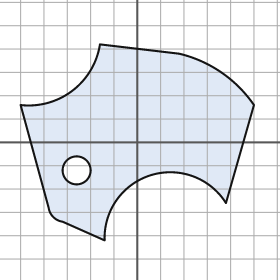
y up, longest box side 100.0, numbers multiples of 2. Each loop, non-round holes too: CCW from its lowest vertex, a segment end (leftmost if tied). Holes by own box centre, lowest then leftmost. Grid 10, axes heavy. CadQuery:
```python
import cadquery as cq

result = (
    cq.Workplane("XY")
    .moveTo(-14.0, -42.0)
    .threePointArc((6.0, -14.0), (38.0, -26.0))
    .lineTo(50.0, 16.0)
    .threePointArc((36.0, 30.0), (18.0, 38.0))
    .lineTo(-16.0, 42.0)
    .threePointArc((-28.0, 22.0), (-50.0, 16.0))
    .lineTo(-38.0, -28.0)
    .threePointArc((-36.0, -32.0), (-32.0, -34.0))
    .close()
    .moveTo(-26.0, -12.0)
    .circle(6.0)
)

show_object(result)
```